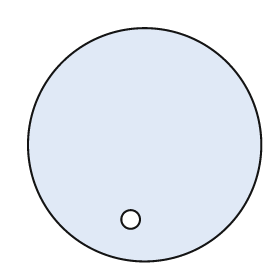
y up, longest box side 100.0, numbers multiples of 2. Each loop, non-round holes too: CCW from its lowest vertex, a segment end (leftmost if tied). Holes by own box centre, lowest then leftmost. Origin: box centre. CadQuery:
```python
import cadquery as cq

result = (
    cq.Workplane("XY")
    .moveTo(0.0, 0.0)
    .circle(50.0)
    .moveTo(-6.0, -32.0)
    .circle(4.0)
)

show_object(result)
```